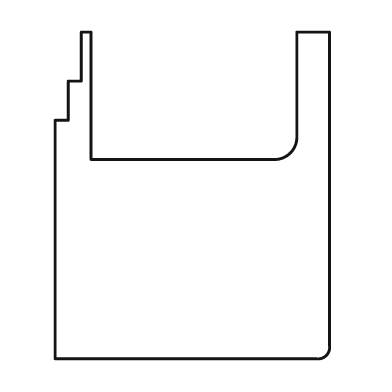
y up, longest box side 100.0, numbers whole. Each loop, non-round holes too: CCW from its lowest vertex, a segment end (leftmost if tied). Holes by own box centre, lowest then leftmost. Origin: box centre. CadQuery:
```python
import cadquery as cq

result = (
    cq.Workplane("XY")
    .moveTo(-42.0, -50.0)
    .lineTo(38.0, -50.0)
    .threePointArc((41.0, -49.0), (42.0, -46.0))
    .lineTo(42.0, 50.0)
    .lineTo(32.0, 50.0)
    .lineTo(32.0, 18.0)
    .threePointArc((30.0, 13.0), (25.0, 11.0))
    .lineTo(-31.0, 11.0)
    .lineTo(-31.0, 50.0)
    .lineTo(-34.0, 50.0)
    .lineTo(-34.0, 35.0)
    .lineTo(-38.0, 35.0)
    .lineTo(-38.0, 23.0)
    .lineTo(-42.0, 23.0)
    .close()
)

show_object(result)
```